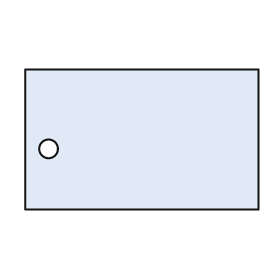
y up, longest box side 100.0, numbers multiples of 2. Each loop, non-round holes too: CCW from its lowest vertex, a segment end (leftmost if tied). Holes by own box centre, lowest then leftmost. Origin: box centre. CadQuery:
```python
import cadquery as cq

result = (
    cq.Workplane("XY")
    .moveTo(-50.0, -30.0)
    .lineTo(50.0, -30.0)
    .lineTo(50.0, 30.0)
    .lineTo(-50.0, 30.0)
    .close()
    .moveTo(-40.0, -4.0)
    .circle(4.0)
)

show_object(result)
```